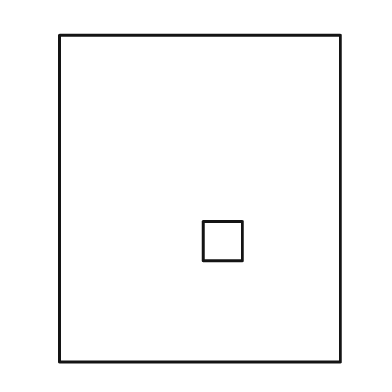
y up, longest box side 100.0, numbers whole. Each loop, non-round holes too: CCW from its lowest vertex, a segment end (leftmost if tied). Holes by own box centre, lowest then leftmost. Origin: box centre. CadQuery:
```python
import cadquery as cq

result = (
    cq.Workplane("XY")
    .moveTo(-43.0, -50.0)
    .lineTo(43.0, -50.0)
    .lineTo(43.0, 50.0)
    .lineTo(-43.0, 50.0)
    .close()
    .moveTo(1.0, -19.0)
    .lineTo(13.0, -19.0)
    .lineTo(13.0, -7.0)
    .lineTo(1.0, -7.0)
    .close()
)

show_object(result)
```